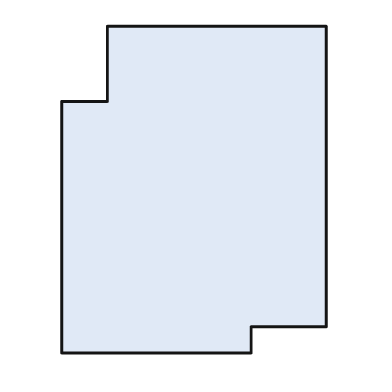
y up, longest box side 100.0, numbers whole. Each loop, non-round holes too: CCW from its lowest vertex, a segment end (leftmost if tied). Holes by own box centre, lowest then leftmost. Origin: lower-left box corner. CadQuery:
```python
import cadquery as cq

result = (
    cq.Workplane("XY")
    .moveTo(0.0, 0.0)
    .lineTo(58.0, 0.0)
    .lineTo(58.0, 8.0)
    .lineTo(81.0, 8.0)
    .lineTo(81.0, 100.0)
    .lineTo(14.0, 100.0)
    .lineTo(14.0, 77.0)
    .lineTo(0.0, 77.0)
    .close()
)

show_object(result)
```